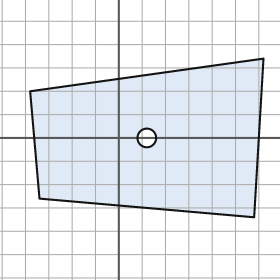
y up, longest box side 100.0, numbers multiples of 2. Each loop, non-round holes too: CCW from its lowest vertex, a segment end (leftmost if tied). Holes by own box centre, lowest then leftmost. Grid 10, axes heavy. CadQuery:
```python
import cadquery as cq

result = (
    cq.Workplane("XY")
    .moveTo(58.0, -34.0)
    .lineTo(62.0, 34.0)
    .lineTo(-38.0, 20.0)
    .lineTo(-34.0, -26.0)
    .close()
    .moveTo(12.0, 0.0)
    .circle(4.0)
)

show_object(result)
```